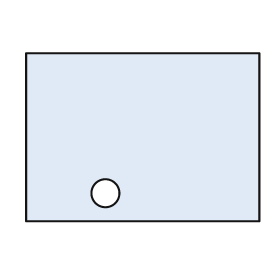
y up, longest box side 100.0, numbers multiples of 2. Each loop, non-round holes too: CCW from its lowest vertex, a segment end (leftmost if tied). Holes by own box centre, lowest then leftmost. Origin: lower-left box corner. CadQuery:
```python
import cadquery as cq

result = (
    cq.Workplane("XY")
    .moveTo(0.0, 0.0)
    .lineTo(100.0, 0.0)
    .lineTo(100.0, 72.0)
    .lineTo(0.0, 72.0)
    .close()
    .moveTo(34.0, 12.0)
    .circle(6.0)
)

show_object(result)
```